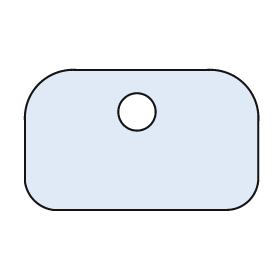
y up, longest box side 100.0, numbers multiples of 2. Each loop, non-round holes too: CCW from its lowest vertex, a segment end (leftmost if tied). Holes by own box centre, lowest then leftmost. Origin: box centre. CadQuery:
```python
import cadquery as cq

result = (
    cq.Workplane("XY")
    .moveTo(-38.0, -30.0)
    .lineTo(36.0, -30.0)
    .threePointArc((46.0, -26.0), (50.0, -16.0))
    .lineTo(50.0, 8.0)
    .threePointArc((44.0, 24.0), (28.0, 30.0))
    .lineTo(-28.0, 30.0)
    .threePointArc((-44.0, 24.0), (-50.0, 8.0))
    .lineTo(-50.0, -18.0)
    .threePointArc((-46.0, -26.0), (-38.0, -30.0))
    .close()
    .moveTo(-2.0, 12.0)
    .circle(8.0)
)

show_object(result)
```